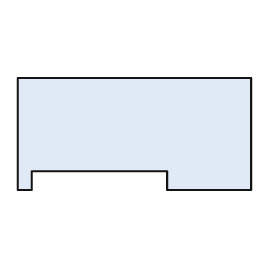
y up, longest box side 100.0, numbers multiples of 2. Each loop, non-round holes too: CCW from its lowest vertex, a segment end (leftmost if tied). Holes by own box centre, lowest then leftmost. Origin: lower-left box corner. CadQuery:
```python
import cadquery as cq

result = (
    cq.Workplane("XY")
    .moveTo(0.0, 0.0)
    .lineTo(6.0, 0.0)
    .lineTo(6.0, 8.0)
    .lineTo(64.0, 8.0)
    .lineTo(64.0, 0.0)
    .lineTo(100.0, 0.0)
    .lineTo(100.0, 48.0)
    .lineTo(0.0, 48.0)
    .close()
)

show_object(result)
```